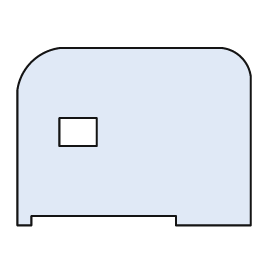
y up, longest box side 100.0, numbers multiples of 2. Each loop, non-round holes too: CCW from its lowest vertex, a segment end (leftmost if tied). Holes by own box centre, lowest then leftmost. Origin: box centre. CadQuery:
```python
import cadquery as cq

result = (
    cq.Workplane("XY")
    .moveTo(-50.0, -38.0)
    .lineTo(-44.0, -38.0)
    .lineTo(-44.0, -34.0)
    .lineTo(18.0, -34.0)
    .lineTo(18.0, -38.0)
    .lineTo(50.0, -38.0)
    .lineTo(50.0, 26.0)
    .threePointArc((46.0, 34.0), (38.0, 38.0))
    .lineTo(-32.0, 38.0)
    .threePointArc((-44.0, 32.0), (-50.0, 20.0))
    .close()
    .moveTo(-32.0, -4.0)
    .lineTo(-16.0, -4.0)
    .lineTo(-16.0, 8.0)
    .lineTo(-32.0, 8.0)
    .close()
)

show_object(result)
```